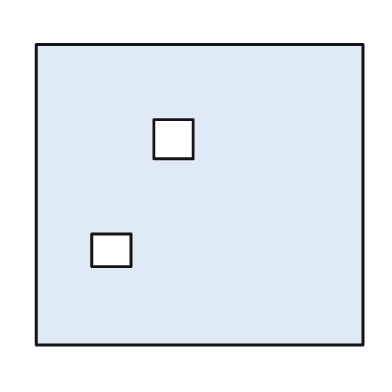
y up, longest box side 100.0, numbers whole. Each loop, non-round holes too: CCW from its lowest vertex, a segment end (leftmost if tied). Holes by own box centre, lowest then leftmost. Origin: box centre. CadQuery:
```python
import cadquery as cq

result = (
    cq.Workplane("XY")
    .moveTo(-50.0, -46.0)
    .lineTo(50.0, -46.0)
    .lineTo(50.0, 46.0)
    .lineTo(-50.0, 46.0)
    .close()
    .moveTo(-33.0, -22.0)
    .lineTo(-21.0, -22.0)
    .lineTo(-21.0, -12.0)
    .lineTo(-33.0, -12.0)
    .close()
    .moveTo(-14.0, 11.0)
    .lineTo(-2.0, 11.0)
    .lineTo(-2.0, 23.0)
    .lineTo(-14.0, 23.0)
    .close()
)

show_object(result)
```